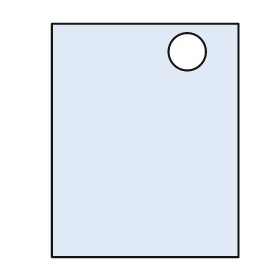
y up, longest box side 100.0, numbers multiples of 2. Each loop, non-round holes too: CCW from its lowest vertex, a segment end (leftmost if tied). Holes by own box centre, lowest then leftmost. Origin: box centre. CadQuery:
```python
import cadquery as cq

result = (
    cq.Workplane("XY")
    .moveTo(-40.0, -50.0)
    .lineTo(40.0, -50.0)
    .lineTo(40.0, 50.0)
    .lineTo(-40.0, 50.0)
    .close()
    .moveTo(18.0, 38.0)
    .circle(8.0)
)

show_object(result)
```